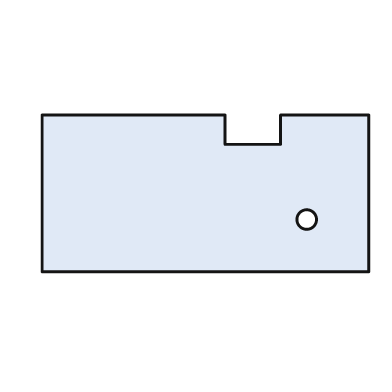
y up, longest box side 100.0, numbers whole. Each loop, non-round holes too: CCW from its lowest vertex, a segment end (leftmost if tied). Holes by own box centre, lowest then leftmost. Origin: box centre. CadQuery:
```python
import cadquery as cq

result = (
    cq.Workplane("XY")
    .moveTo(-50.0, -24.0)
    .lineTo(50.0, -24.0)
    .lineTo(50.0, 24.0)
    .lineTo(23.0, 24.0)
    .lineTo(23.0, 15.0)
    .lineTo(6.0, 15.0)
    .lineTo(6.0, 24.0)
    .lineTo(-50.0, 24.0)
    .close()
    .moveTo(31.0, -8.0)
    .circle(3.0)
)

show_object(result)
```